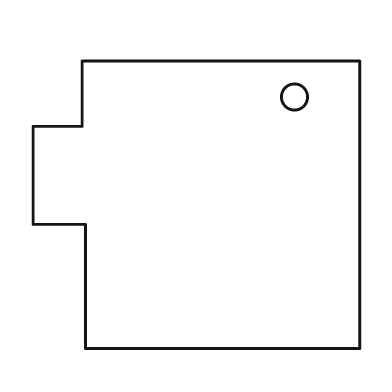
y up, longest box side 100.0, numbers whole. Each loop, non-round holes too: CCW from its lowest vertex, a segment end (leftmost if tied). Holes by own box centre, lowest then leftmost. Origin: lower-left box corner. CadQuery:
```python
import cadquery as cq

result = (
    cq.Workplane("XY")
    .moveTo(16.0, 0.0)
    .lineTo(100.0, 0.0)
    .lineTo(100.0, 88.0)
    .lineTo(15.0, 88.0)
    .lineTo(15.0, 68.0)
    .lineTo(0.0, 68.0)
    .lineTo(0.0, 38.0)
    .lineTo(16.0, 38.0)
    .close()
    .moveTo(80.0, 77.0)
    .circle(4.0)
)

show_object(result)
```